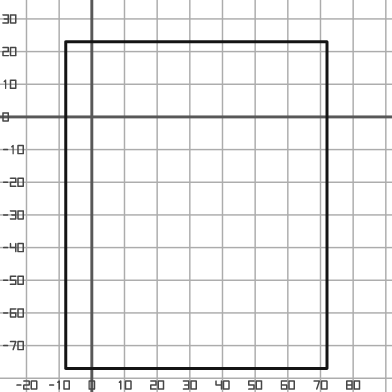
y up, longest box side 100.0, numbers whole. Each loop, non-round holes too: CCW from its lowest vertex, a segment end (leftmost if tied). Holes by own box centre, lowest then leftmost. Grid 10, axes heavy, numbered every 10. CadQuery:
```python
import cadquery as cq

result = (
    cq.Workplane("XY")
    .moveTo(-8.0, -77.0)
    .lineTo(72.0, -77.0)
    .lineTo(72.0, 23.0)
    .lineTo(-8.0, 23.0)
    .close()
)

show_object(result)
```